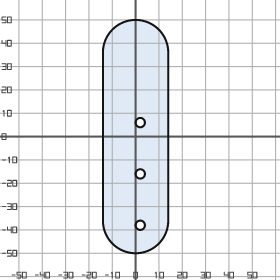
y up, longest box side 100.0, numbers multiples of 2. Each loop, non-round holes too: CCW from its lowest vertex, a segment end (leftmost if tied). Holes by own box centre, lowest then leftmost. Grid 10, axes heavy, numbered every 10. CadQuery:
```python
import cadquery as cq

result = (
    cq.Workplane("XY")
    .moveTo(-14.0, -36.0)
    .threePointArc((0.0, -50.0), (14.0, -36.0))
    .lineTo(14.0, 36.0)
    .threePointArc((0.0, 50.0), (-14.0, 36.0))
    .close()
    .moveTo(2.0, -38.0)
    .circle(2.0)
    .moveTo(2.0, -16.0)
    .circle(2.0)
    .moveTo(2.0, 6.0)
    .circle(2.0)
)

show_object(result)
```